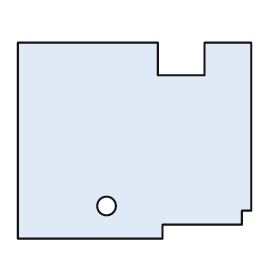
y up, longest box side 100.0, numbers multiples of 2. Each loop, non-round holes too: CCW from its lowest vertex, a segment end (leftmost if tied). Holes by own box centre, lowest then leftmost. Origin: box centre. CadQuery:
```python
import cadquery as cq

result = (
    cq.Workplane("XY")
    .moveTo(-50.0, -42.0)
    .lineTo(12.0, -42.0)
    .lineTo(12.0, -36.0)
    .lineTo(46.0, -36.0)
    .lineTo(46.0, -30.0)
    .lineTo(50.0, -30.0)
    .lineTo(50.0, 42.0)
    .lineTo(30.0, 42.0)
    .lineTo(30.0, 28.0)
    .lineTo(10.0, 28.0)
    .lineTo(10.0, 42.0)
    .lineTo(-50.0, 42.0)
    .close()
    .moveTo(-12.0, -28.0)
    .circle(4.0)
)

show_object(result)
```